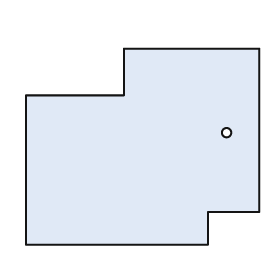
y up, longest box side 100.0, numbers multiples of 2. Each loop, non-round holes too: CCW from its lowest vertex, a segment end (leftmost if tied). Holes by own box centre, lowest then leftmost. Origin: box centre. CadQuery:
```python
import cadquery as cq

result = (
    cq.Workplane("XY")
    .moveTo(-50.0, -42.0)
    .lineTo(28.0, -42.0)
    .lineTo(28.0, -28.0)
    .lineTo(50.0, -28.0)
    .lineTo(50.0, 42.0)
    .lineTo(-8.0, 42.0)
    .lineTo(-8.0, 22.0)
    .lineTo(-50.0, 22.0)
    .close()
    .moveTo(36.0, 6.0)
    .circle(2.0)
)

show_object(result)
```